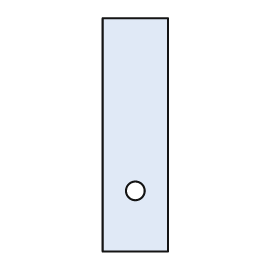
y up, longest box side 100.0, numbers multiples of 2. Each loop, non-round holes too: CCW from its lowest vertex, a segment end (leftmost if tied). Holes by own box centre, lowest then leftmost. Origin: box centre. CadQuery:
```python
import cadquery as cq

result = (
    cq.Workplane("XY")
    .moveTo(-14.0, -50.0)
    .lineTo(14.0, -50.0)
    .lineTo(14.0, 50.0)
    .lineTo(-14.0, 50.0)
    .close()
    .moveTo(0.0, -24.0)
    .circle(4.0)
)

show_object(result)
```